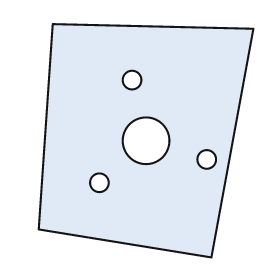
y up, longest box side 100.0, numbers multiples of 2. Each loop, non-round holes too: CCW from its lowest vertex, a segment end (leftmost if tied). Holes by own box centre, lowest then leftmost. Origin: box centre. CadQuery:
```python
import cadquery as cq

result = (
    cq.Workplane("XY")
    .moveTo(28.0, -50.0)
    .lineTo(46.0, 48.0)
    .lineTo(-40.0, 50.0)
    .lineTo(-46.0, -38.0)
    .close()
    .moveTo(-20.0, -18.0)
    .circle(4.0)
    .moveTo(26.0, -8.0)
    .circle(4.0)
    .moveTo(0.0, 0.0)
    .circle(10.0)
    .moveTo(-6.0, 26.0)
    .circle(4.0)
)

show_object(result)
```